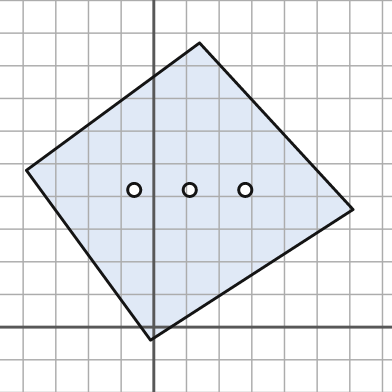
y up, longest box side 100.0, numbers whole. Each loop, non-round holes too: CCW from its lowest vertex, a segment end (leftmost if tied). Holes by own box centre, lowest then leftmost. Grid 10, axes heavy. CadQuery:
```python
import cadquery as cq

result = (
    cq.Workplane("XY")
    .moveTo(-1.0, -4.0)
    .lineTo(61.0, 36.0)
    .lineTo(14.0, 87.0)
    .lineTo(-39.0, 48.0)
    .close()
    .moveTo(-6.0, 42.0)
    .circle(2.0)
    .moveTo(11.0, 42.0)
    .circle(2.0)
    .moveTo(28.0, 42.0)
    .circle(2.0)
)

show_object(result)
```